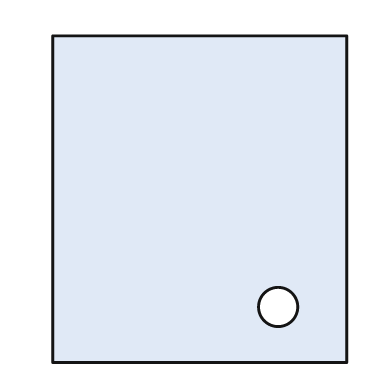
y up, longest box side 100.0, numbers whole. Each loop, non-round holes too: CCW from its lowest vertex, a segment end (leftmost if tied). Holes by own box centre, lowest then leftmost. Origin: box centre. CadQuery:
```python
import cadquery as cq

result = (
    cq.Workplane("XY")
    .moveTo(-45.0, -50.0)
    .lineTo(45.0, -50.0)
    .lineTo(45.0, 50.0)
    .lineTo(-45.0, 50.0)
    .close()
    .moveTo(24.0, -33.0)
    .circle(6.0)
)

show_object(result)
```